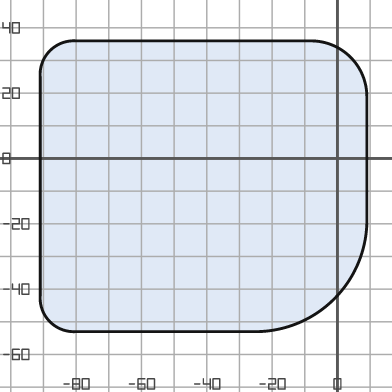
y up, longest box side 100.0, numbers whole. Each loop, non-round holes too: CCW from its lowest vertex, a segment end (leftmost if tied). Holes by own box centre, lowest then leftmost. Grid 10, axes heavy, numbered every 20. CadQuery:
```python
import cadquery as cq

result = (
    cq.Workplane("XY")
    .moveTo(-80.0, -53.0)
    .lineTo(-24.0, -53.0)
    .threePointArc((-1.0, -43.0), (9.0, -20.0))
    .lineTo(9.0, 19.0)
    .threePointArc((4.0, 31.0), (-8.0, 36.0))
    .lineTo(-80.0, 36.0)
    .threePointArc((-88.0, 33.0), (-91.0, 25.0))
    .lineTo(-91.0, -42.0)
    .threePointArc((-88.0, -50.0), (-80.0, -53.0))
    .close()
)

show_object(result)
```